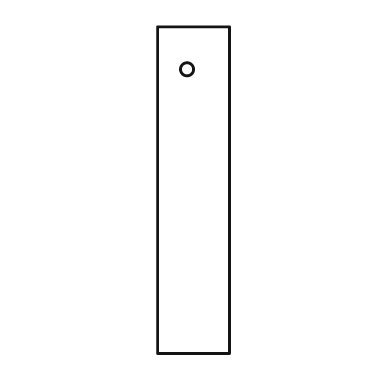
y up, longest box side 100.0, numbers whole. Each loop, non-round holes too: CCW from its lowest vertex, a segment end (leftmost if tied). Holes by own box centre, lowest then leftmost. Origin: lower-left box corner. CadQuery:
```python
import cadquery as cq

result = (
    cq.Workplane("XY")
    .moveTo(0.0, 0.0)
    .lineTo(22.0, 0.0)
    .lineTo(22.0, 100.0)
    .lineTo(0.0, 100.0)
    .close()
    .moveTo(9.0, 87.0)
    .circle(2.0)
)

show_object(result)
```